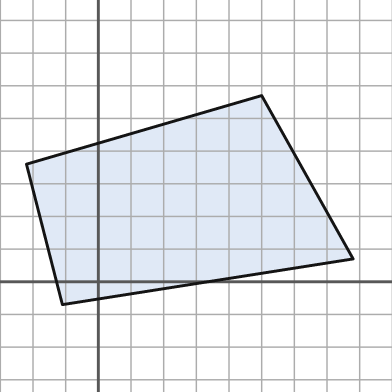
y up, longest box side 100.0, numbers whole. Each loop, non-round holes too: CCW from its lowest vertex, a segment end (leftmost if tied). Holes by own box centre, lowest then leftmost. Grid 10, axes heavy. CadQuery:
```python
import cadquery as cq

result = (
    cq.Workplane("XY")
    .moveTo(-11.0, -7.0)
    .lineTo(78.0, 7.0)
    .lineTo(50.0, 57.0)
    .lineTo(-22.0, 36.0)
    .close()
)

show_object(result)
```